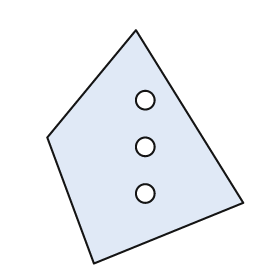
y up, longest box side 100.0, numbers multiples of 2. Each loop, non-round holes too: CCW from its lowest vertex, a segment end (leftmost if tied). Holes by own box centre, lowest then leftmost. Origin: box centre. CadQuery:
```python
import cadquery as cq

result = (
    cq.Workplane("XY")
    .moveTo(-22.0, -50.0)
    .lineTo(42.0, -24.0)
    .lineTo(-4.0, 50.0)
    .lineTo(-42.0, 4.0)
    .close()
    .moveTo(0.0, -20.0)
    .circle(4.0)
    .moveTo(0.0, 0.0)
    .circle(4.0)
    .moveTo(0.0, 20.0)
    .circle(4.0)
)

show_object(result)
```